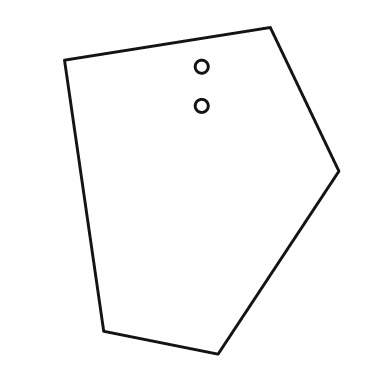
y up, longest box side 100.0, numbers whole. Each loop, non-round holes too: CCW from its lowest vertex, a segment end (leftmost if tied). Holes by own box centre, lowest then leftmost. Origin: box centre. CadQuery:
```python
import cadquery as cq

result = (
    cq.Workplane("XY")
    .moveTo(5.0, -50.0)
    .lineTo(42.0, 6.0)
    .lineTo(21.0, 50.0)
    .lineTo(-42.0, 40.0)
    .lineTo(-30.0, -43.0)
    .close()
    .moveTo(0.0, 26.0)
    .circle(2.0)
    .moveTo(0.0, 38.0)
    .circle(2.0)
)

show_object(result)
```